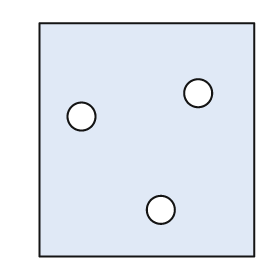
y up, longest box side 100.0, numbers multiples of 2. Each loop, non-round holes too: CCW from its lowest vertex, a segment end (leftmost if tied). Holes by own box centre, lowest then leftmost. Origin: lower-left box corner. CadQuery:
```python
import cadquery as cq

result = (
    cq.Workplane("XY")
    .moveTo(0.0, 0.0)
    .lineTo(92.0, 0.0)
    .lineTo(92.0, 100.0)
    .lineTo(0.0, 100.0)
    .close()
    .moveTo(52.0, 20.0)
    .circle(6.0)
    .moveTo(18.0, 60.0)
    .circle(6.0)
    .moveTo(68.0, 70.0)
    .circle(6.0)
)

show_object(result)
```